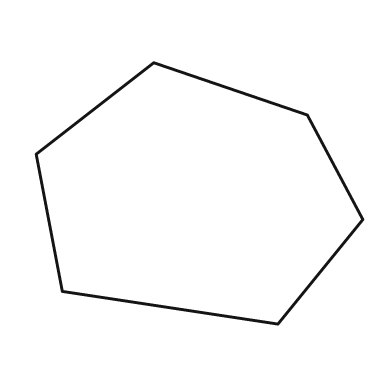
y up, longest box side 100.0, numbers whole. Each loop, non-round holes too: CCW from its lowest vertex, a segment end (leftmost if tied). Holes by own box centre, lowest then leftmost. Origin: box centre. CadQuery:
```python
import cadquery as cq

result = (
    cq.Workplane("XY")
    .moveTo(24.0, -40.0)
    .lineTo(50.0, -8.0)
    .lineTo(33.0, 24.0)
    .lineTo(-14.0, 40.0)
    .lineTo(-50.0, 12.0)
    .lineTo(-42.0, -30.0)
    .close()
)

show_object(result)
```